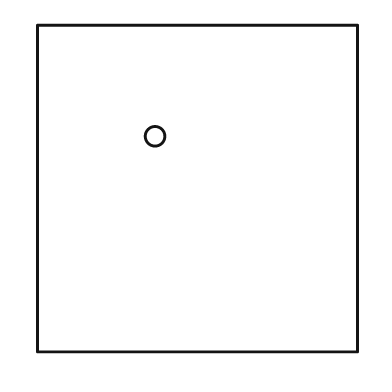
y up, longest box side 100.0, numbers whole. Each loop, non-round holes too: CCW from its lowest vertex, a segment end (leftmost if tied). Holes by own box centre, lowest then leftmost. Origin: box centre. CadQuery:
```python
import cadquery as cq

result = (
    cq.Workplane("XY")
    .moveTo(-49.0, -50.0)
    .lineTo(49.0, -50.0)
    .lineTo(49.0, 50.0)
    .lineTo(-49.0, 50.0)
    .close()
    .moveTo(-13.0, 16.0)
    .circle(3.0)
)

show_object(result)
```